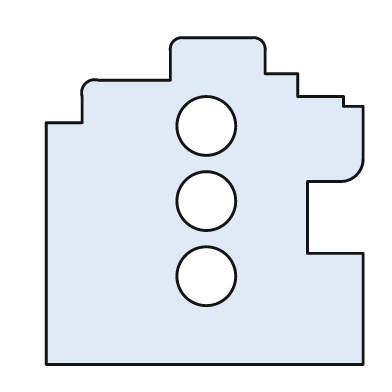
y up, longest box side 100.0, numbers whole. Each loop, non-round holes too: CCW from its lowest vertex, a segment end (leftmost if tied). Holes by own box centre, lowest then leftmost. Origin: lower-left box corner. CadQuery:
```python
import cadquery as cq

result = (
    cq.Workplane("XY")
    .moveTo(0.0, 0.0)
    .lineTo(97.0, 0.0)
    .lineTo(97.0, 34.0)
    .lineTo(80.0, 34.0)
    .lineTo(80.0, 56.0)
    .lineTo(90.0, 56.0)
    .threePointArc((95.0, 58.0), (97.0, 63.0))
    .lineTo(97.0, 79.0)
    .lineTo(91.0, 79.0)
    .lineTo(91.0, 82.0)
    .lineTo(77.0, 82.0)
    .lineTo(77.0, 89.0)
    .lineTo(67.0, 89.0)
    .lineTo(67.0, 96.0)
    .threePointArc((66.0, 99.0), (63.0, 100.0))
    .lineTo(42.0, 100.0)
    .threePointArc((39.0, 99.0), (38.0, 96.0))
    .lineTo(38.0, 87.0)
    .lineTo(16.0, 87.0)
    .threePointArc((12.0, 86.0), (11.0, 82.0))
    .lineTo(11.0, 74.0)
    .lineTo(0.0, 74.0)
    .close()
    .moveTo(49.0, 27.0)
    .circle(9.0)
    .moveTo(49.0, 50.0)
    .circle(9.0)
    .moveTo(49.0, 73.0)
    .circle(9.0)
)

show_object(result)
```